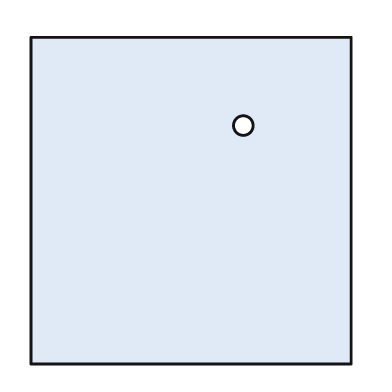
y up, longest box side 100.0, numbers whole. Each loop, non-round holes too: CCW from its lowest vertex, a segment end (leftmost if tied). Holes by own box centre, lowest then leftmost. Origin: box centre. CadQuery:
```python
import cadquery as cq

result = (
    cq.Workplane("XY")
    .moveTo(-49.0, -50.0)
    .lineTo(49.0, -50.0)
    .lineTo(49.0, 50.0)
    .lineTo(-49.0, 50.0)
    .close()
    .moveTo(16.0, 23.0)
    .circle(3.0)
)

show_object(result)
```